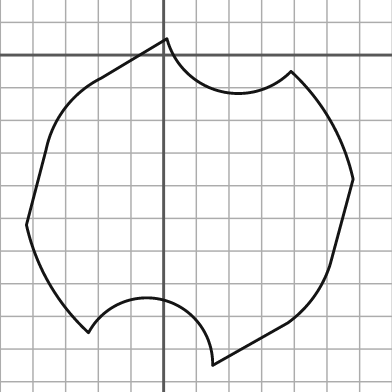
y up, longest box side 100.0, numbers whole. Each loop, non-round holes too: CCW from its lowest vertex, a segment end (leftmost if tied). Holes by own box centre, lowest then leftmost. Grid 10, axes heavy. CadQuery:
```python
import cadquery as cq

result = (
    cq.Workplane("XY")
    .moveTo(15.0, -95.0)
    .lineTo(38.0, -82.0)
    .threePointArc((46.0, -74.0), (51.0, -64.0))
    .lineTo(58.0, -38.0)
    .threePointArc((51.0, -20.0), (39.0, -5.0))
    .threePointArc((17.0, -11.0), (1.0, 5.0))
    .lineTo(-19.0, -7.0)
    .threePointArc((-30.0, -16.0), (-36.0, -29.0))
    .lineTo(-42.0, -52.0)
    .threePointArc((-35.0, -70.0), (-23.0, -85.0))
    .threePointArc((0.0, -75.0), (15.0, -95.0))
    .close()
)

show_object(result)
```